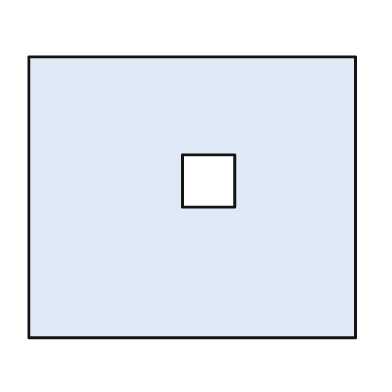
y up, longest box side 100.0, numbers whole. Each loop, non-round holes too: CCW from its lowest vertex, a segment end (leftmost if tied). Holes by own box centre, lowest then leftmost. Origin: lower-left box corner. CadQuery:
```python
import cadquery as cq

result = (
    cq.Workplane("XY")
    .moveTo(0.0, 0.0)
    .lineTo(100.0, 0.0)
    .lineTo(100.0, 86.0)
    .lineTo(0.0, 86.0)
    .close()
    .moveTo(47.0, 40.0)
    .lineTo(63.0, 40.0)
    .lineTo(63.0, 56.0)
    .lineTo(47.0, 56.0)
    .close()
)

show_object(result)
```